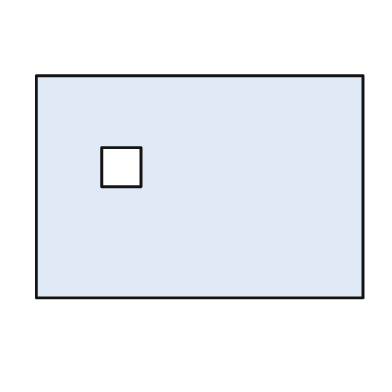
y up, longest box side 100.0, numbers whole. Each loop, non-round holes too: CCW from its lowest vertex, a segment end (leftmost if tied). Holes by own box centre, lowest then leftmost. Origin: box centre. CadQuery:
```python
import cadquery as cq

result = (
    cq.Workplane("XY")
    .moveTo(-50.0, -34.0)
    .lineTo(50.0, -34.0)
    .lineTo(50.0, 34.0)
    .lineTo(-50.0, 34.0)
    .close()
    .moveTo(-30.0, 0.0)
    .lineTo(-18.0, 0.0)
    .lineTo(-18.0, 12.0)
    .lineTo(-30.0, 12.0)
    .close()
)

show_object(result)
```